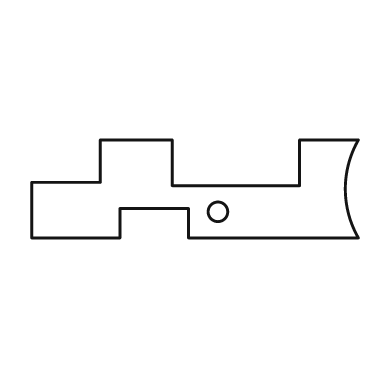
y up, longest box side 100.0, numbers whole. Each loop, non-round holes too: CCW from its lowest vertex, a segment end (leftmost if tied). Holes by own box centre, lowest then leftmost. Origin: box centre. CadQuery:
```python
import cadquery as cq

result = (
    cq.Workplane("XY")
    .moveTo(-50.0, -15.0)
    .lineTo(-23.0, -15.0)
    .lineTo(-23.0, -6.0)
    .lineTo(-2.0, -6.0)
    .lineTo(-2.0, -15.0)
    .lineTo(50.0, -15.0)
    .threePointArc((46.0, 0.0), (50.0, 15.0))
    .lineTo(32.0, 15.0)
    .lineTo(32.0, 1.0)
    .lineTo(-7.0, 1.0)
    .lineTo(-7.0, 15.0)
    .lineTo(-29.0, 15.0)
    .lineTo(-29.0, 2.0)
    .lineTo(-50.0, 2.0)
    .close()
    .moveTo(7.0, -7.0)
    .circle(3.0)
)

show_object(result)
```